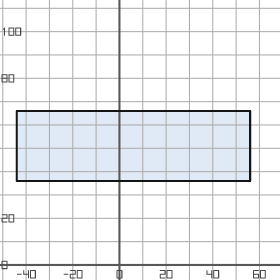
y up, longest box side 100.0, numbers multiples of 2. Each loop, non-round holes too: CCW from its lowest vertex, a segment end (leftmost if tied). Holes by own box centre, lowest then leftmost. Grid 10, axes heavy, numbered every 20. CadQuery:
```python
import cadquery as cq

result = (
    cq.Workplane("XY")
    .moveTo(-44.0, 36.0)
    .lineTo(56.0, 36.0)
    .lineTo(56.0, 66.0)
    .lineTo(-44.0, 66.0)
    .close()
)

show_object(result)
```